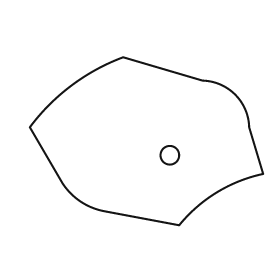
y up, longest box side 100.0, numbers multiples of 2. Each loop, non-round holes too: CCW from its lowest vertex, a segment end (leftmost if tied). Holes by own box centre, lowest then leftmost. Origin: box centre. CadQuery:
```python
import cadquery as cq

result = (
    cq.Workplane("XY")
    .moveTo(14.0, -36.0)
    .threePointArc((30.0, -22.0), (50.0, -14.0))
    .lineTo(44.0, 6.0)
    .threePointArc((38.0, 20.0), (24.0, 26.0))
    .lineTo(-10.0, 36.0)
    .threePointArc((-32.0, 24.0), (-50.0, 6.0))
    .lineTo(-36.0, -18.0)
    .threePointArc((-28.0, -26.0), (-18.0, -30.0))
    .close()
    .moveTo(10.0, -6.0)
    .circle(4.0)
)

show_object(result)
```